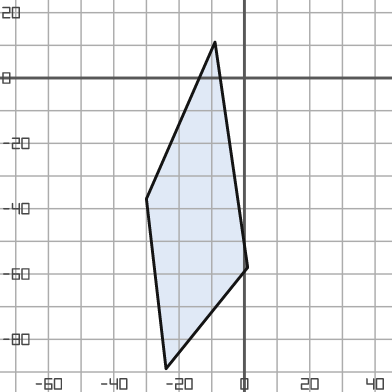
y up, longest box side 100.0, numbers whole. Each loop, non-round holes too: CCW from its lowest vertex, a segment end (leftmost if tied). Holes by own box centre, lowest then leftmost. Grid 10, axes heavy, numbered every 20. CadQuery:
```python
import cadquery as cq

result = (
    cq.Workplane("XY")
    .moveTo(-24.0, -89.0)
    .lineTo(1.0, -58.0)
    .lineTo(-9.0, 11.0)
    .lineTo(-30.0, -37.0)
    .close()
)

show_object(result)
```